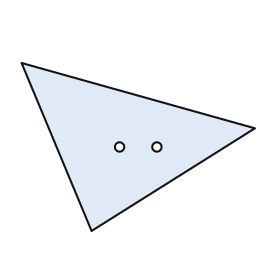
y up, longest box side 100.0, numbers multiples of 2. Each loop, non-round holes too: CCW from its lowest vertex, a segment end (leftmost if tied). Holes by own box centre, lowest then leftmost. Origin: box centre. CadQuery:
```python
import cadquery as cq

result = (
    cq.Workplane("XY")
    .moveTo(-20.0, -36.0)
    .lineTo(50.0, 8.0)
    .lineTo(-50.0, 36.0)
    .close()
    .moveTo(-8.0, 0.0)
    .circle(2.0)
    .moveTo(8.0, 0.0)
    .circle(2.0)
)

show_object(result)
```